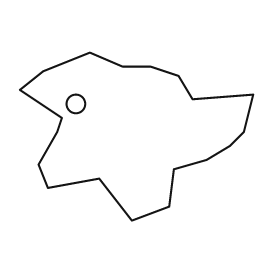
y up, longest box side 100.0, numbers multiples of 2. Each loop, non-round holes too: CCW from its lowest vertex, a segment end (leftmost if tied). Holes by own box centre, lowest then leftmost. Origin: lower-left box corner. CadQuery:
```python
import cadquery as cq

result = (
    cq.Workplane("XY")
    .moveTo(48.0, 0.0)
    .lineTo(64.0, 6.0)
    .lineTo(66.0, 22.0)
    .lineTo(80.0, 26.0)
    .lineTo(90.0, 32.0)
    .lineTo(96.0, 38.0)
    .lineTo(100.0, 54.0)
    .lineTo(74.0, 52.0)
    .lineTo(68.0, 62.0)
    .lineTo(56.0, 66.0)
    .lineTo(44.0, 66.0)
    .lineTo(30.0, 72.0)
    .lineTo(10.0, 64.0)
    .lineTo(0.0, 56.0)
    .lineTo(18.0, 44.0)
    .lineTo(16.0, 38.0)
    .lineTo(8.0, 24.0)
    .lineTo(12.0, 14.0)
    .lineTo(34.0, 18.0)
    .close()
    .moveTo(24.0, 50.0)
    .circle(4.0)
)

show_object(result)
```